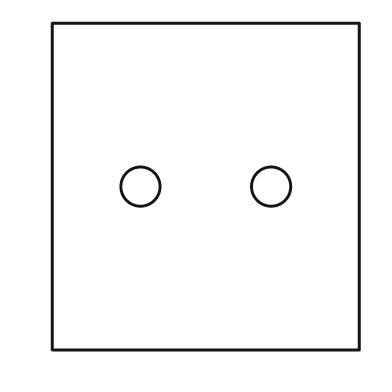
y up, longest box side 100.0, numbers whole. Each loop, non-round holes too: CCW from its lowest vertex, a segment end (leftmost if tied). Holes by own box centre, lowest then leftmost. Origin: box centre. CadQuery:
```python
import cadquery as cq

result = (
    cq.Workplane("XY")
    .moveTo(-47.0, -50.0)
    .lineTo(47.0, -50.0)
    .lineTo(47.0, 50.0)
    .lineTo(-47.0, 50.0)
    .close()
    .moveTo(-20.0, 0.0)
    .circle(6.0)
    .moveTo(20.0, 0.0)
    .circle(6.0)
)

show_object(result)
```